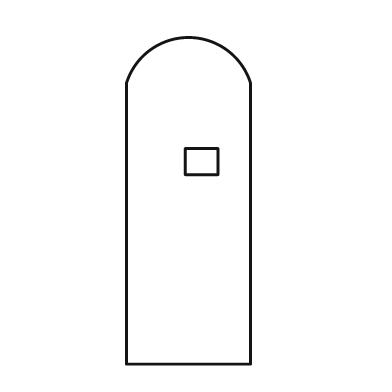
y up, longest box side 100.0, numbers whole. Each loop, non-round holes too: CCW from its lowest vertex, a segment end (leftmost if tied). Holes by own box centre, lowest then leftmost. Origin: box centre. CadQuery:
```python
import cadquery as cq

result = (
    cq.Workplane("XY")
    .moveTo(-19.0, -50.0)
    .lineTo(19.0, -50.0)
    .lineTo(19.0, 36.0)
    .threePointArc((0.0, 50.0), (-19.0, 36.0))
    .close()
    .moveTo(-1.0, 8.0)
    .lineTo(9.0, 8.0)
    .lineTo(9.0, 16.0)
    .lineTo(-1.0, 16.0)
    .close()
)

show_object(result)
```